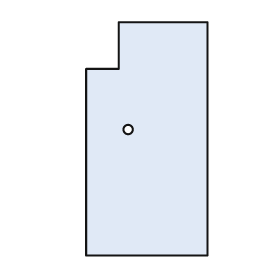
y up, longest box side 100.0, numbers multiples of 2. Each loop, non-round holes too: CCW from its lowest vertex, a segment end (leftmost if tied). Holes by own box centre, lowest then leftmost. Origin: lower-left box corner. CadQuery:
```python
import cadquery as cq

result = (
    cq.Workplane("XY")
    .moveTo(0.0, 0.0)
    .lineTo(52.0, 0.0)
    .lineTo(52.0, 100.0)
    .lineTo(14.0, 100.0)
    .lineTo(14.0, 80.0)
    .lineTo(0.0, 80.0)
    .close()
    .moveTo(18.0, 54.0)
    .circle(2.0)
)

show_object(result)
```